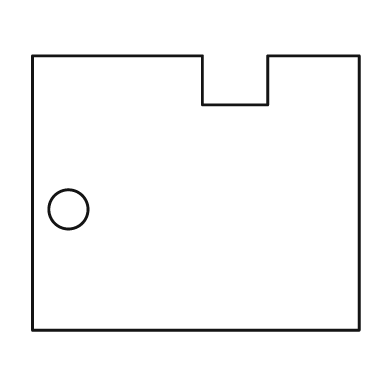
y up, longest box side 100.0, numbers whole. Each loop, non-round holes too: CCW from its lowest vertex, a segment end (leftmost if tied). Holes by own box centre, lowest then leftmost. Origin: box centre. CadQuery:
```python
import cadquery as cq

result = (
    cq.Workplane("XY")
    .moveTo(-50.0, -42.0)
    .lineTo(50.0, -42.0)
    .lineTo(50.0, 42.0)
    .lineTo(22.0, 42.0)
    .lineTo(22.0, 27.0)
    .lineTo(2.0, 27.0)
    .lineTo(2.0, 42.0)
    .lineTo(-50.0, 42.0)
    .close()
    .moveTo(-39.0, -5.0)
    .circle(6.0)
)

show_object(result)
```